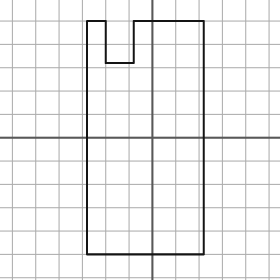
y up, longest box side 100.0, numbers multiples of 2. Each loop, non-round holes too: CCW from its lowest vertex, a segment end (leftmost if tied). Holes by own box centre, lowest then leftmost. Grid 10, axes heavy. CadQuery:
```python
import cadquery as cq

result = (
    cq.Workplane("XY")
    .moveTo(-28.0, -50.0)
    .lineTo(22.0, -50.0)
    .lineTo(22.0, 50.0)
    .lineTo(-8.0, 50.0)
    .lineTo(-8.0, 32.0)
    .lineTo(-20.0, 32.0)
    .lineTo(-20.0, 50.0)
    .lineTo(-28.0, 50.0)
    .close()
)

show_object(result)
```